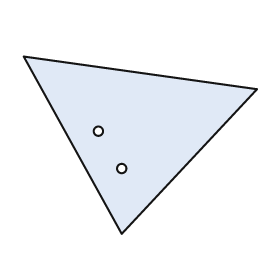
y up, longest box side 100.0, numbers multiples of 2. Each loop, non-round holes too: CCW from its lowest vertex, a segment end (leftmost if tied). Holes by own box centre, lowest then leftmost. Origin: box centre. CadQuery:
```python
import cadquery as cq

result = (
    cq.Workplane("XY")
    .moveTo(-8.0, -38.0)
    .lineTo(50.0, 24.0)
    .lineTo(-50.0, 38.0)
    .close()
    .moveTo(-8.0, -10.0)
    .circle(2.0)
    .moveTo(-18.0, 6.0)
    .circle(2.0)
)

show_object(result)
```